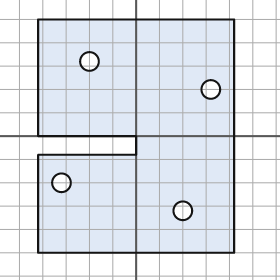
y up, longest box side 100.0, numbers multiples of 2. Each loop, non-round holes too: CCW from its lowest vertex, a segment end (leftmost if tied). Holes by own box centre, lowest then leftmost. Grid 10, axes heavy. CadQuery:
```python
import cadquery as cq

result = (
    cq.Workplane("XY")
    .moveTo(-42.0, -50.0)
    .lineTo(42.0, -50.0)
    .lineTo(42.0, 50.0)
    .lineTo(-42.0, 50.0)
    .lineTo(-42.0, 0.0)
    .lineTo(0.0, 0.0)
    .lineTo(0.0, -8.0)
    .lineTo(-42.0, -8.0)
    .close()
    .moveTo(20.0, -32.0)
    .circle(4.0)
    .moveTo(-32.0, -20.0)
    .circle(4.0)
    .moveTo(32.0, 20.0)
    .circle(4.0)
    .moveTo(-20.0, 32.0)
    .circle(4.0)
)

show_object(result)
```